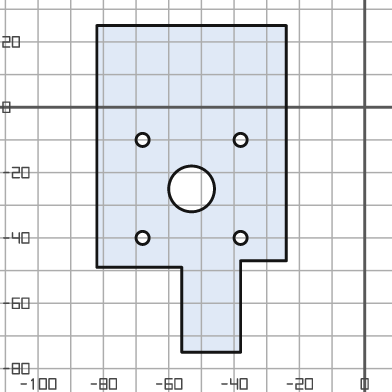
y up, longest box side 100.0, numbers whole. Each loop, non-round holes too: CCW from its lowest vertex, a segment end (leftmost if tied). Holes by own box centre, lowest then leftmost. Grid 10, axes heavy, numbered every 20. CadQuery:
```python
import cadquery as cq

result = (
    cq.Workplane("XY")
    .moveTo(-56.0, -75.0)
    .lineTo(-38.0, -75.0)
    .lineTo(-38.0, -47.0)
    .lineTo(-24.0, -47.0)
    .lineTo(-24.0, 25.0)
    .lineTo(-82.0, 25.0)
    .lineTo(-82.0, -49.0)
    .lineTo(-56.0, -49.0)
    .close()
    .moveTo(-68.0, -40.0)
    .circle(2.0)
    .moveTo(-38.0, -40.0)
    .circle(2.0)
    .moveTo(-53.0, -25.0)
    .circle(7.0)
    .moveTo(-68.0, -10.0)
    .circle(2.0)
    .moveTo(-38.0, -10.0)
    .circle(2.0)
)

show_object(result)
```